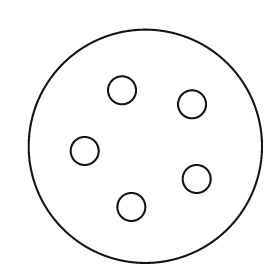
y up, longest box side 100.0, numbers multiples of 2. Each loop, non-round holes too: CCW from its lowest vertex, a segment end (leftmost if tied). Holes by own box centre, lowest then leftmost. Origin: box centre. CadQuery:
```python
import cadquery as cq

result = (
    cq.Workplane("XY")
    .moveTo(0.0, 0.0)
    .circle(50.0)
    .moveTo(-6.0, -26.0)
    .circle(6.0)
    .moveTo(22.0, -14.0)
    .circle(6.0)
    .moveTo(-26.0, -2.0)
    .circle(6.0)
    .moveTo(20.0, 18.0)
    .circle(6.0)
    .moveTo(-10.0, 24.0)
    .circle(6.0)
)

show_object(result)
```